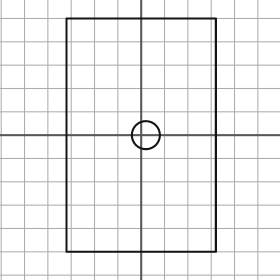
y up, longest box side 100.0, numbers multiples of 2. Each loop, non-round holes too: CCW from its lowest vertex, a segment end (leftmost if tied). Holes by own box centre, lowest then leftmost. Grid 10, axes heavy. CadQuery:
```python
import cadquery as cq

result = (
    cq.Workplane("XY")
    .moveTo(-32.0, -50.0)
    .lineTo(32.0, -50.0)
    .lineTo(32.0, 50.0)
    .lineTo(-32.0, 50.0)
    .close()
    .moveTo(2.0, 0.0)
    .circle(6.0)
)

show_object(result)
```